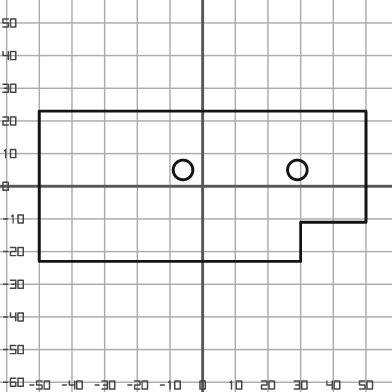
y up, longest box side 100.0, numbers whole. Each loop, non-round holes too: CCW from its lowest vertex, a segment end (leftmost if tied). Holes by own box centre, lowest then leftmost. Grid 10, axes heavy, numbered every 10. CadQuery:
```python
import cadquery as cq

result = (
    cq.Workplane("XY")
    .moveTo(-50.0, -23.0)
    .lineTo(30.0, -23.0)
    .lineTo(30.0, -11.0)
    .lineTo(50.0, -11.0)
    .lineTo(50.0, 23.0)
    .lineTo(-50.0, 23.0)
    .close()
    .moveTo(-6.0, 5.0)
    .circle(3.0)
    .moveTo(29.0, 5.0)
    .circle(3.0)
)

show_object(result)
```